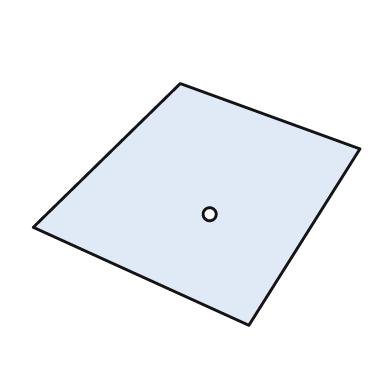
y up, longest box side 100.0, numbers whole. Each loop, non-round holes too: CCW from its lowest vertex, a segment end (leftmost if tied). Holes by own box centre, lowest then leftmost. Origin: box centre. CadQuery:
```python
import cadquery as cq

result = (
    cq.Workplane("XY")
    .moveTo(16.0, -37.0)
    .lineTo(50.0, 17.0)
    .lineTo(-5.0, 37.0)
    .lineTo(-50.0, -7.0)
    .close()
    .moveTo(4.0, -3.0)
    .circle(2.0)
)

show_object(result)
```